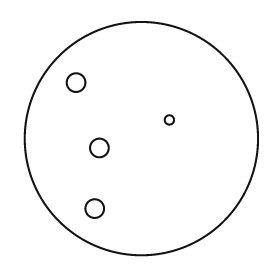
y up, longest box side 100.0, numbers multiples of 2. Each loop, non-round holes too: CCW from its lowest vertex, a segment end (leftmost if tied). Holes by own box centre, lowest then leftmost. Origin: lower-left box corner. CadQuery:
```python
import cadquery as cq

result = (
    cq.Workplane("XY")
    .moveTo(50.0, 50.0)
    .circle(50.0)
    .moveTo(30.0, 20.0)
    .circle(4.0)
    .moveTo(32.0, 46.0)
    .circle(4.0)
    .moveTo(62.0, 58.0)
    .circle(2.0)
    .moveTo(22.0, 74.0)
    .circle(4.0)
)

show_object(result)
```